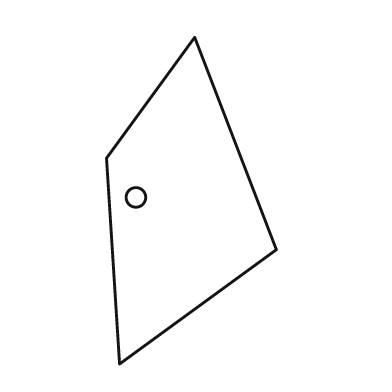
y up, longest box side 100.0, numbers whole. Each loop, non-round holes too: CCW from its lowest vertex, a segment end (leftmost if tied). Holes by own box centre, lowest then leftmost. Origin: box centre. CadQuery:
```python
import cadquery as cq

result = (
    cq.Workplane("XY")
    .moveTo(-22.0, -50.0)
    .lineTo(26.0, -15.0)
    .lineTo(1.0, 50.0)
    .lineTo(-26.0, 13.0)
    .close()
    .moveTo(-17.0, 1.0)
    .circle(3.0)
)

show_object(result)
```